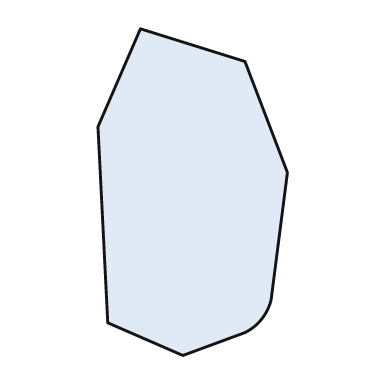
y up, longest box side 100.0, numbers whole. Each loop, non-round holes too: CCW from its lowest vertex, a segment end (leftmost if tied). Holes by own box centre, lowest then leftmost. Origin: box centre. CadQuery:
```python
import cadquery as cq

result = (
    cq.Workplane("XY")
    .moveTo(-3.0, -50.0)
    .lineTo(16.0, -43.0)
    .threePointArc((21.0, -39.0), (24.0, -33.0))
    .lineTo(29.0, 6.0)
    .lineTo(16.0, 40.0)
    .lineTo(-16.0, 50.0)
    .lineTo(-29.0, 20.0)
    .lineTo(-26.0, -40.0)
    .close()
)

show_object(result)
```